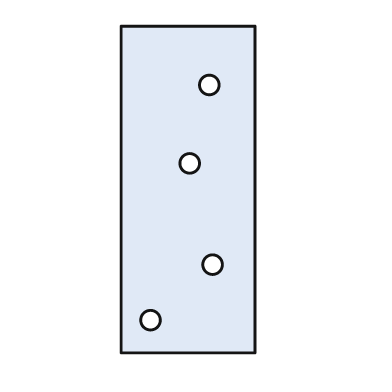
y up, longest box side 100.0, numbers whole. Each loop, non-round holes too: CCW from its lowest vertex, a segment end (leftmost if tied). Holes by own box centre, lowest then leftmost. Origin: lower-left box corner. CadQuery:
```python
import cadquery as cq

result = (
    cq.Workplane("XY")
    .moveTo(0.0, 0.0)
    .lineTo(41.0, 0.0)
    .lineTo(41.0, 100.0)
    .lineTo(0.0, 100.0)
    .close()
    .moveTo(9.0, 10.0)
    .circle(3.0)
    .moveTo(28.0, 27.0)
    .circle(3.0)
    .moveTo(21.0, 58.0)
    .circle(3.0)
    .moveTo(27.0, 82.0)
    .circle(3.0)
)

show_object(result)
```